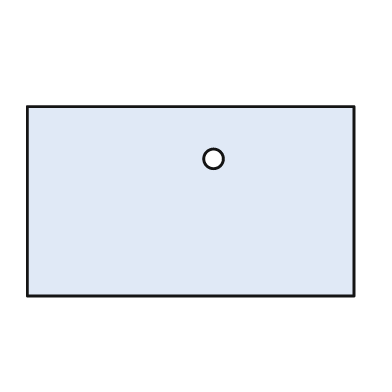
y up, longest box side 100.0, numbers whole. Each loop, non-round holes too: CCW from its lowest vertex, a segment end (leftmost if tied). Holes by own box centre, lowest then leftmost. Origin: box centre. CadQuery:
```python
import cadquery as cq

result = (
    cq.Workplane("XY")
    .moveTo(-50.0, -29.0)
    .lineTo(50.0, -29.0)
    .lineTo(50.0, 29.0)
    .lineTo(-50.0, 29.0)
    .close()
    .moveTo(7.0, 13.0)
    .circle(3.0)
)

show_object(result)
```